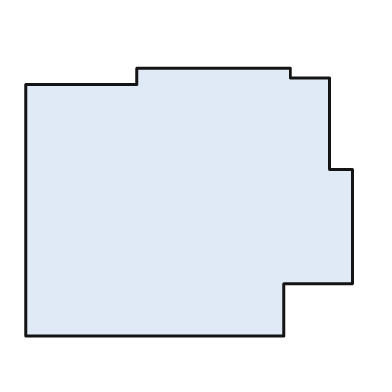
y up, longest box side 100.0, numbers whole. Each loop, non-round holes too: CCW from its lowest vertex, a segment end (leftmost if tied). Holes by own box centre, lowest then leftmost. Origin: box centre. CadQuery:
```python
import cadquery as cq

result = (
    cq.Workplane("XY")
    .moveTo(-50.0, -41.0)
    .lineTo(29.0, -41.0)
    .lineTo(29.0, -25.0)
    .lineTo(50.0, -25.0)
    .lineTo(50.0, 10.0)
    .lineTo(43.0, 10.0)
    .lineTo(43.0, 38.0)
    .lineTo(31.0, 38.0)
    .lineTo(31.0, 41.0)
    .lineTo(-16.0, 41.0)
    .lineTo(-16.0, 36.0)
    .lineTo(-50.0, 36.0)
    .close()
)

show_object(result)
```